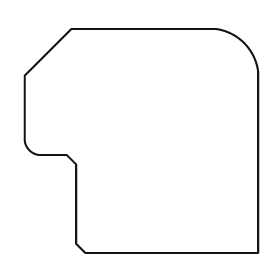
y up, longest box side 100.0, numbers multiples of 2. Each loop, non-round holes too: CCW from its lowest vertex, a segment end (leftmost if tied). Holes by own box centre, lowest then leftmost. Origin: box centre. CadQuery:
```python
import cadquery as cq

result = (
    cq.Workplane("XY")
    .moveTo(-24.0, -48.0)
    .lineTo(50.0, -48.0)
    .lineTo(50.0, 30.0)
    .threePointArc((44.0, 42.0), (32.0, 48.0))
    .lineTo(-30.0, 48.0)
    .lineTo(-50.0, 28.0)
    .lineTo(-50.0, 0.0)
    .threePointArc((-48.0, -4.0), (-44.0, -6.0))
    .lineTo(-32.0, -6.0)
    .lineTo(-28.0, -10.0)
    .lineTo(-28.0, -44.0)
    .close()
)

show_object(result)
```